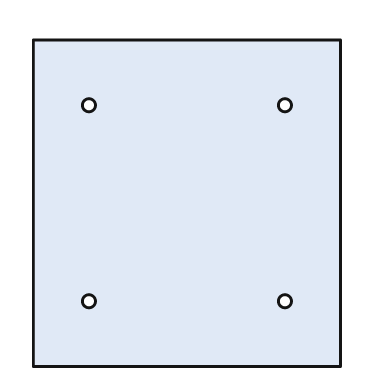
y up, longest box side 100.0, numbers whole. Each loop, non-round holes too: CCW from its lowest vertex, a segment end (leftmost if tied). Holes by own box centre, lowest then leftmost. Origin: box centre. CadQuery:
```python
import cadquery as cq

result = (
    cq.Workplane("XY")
    .moveTo(-47.0, -50.0)
    .lineTo(47.0, -50.0)
    .lineTo(47.0, 50.0)
    .lineTo(-47.0, 50.0)
    .close()
    .moveTo(-30.0, -30.0)
    .circle(2.0)
    .moveTo(30.0, -30.0)
    .circle(2.0)
    .moveTo(-30.0, 30.0)
    .circle(2.0)
    .moveTo(30.0, 30.0)
    .circle(2.0)
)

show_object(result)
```